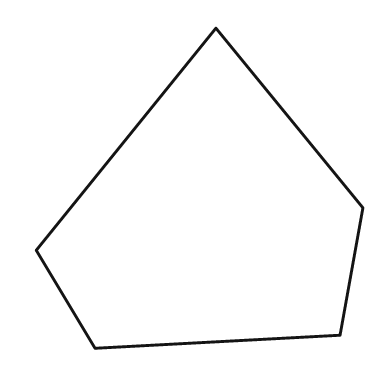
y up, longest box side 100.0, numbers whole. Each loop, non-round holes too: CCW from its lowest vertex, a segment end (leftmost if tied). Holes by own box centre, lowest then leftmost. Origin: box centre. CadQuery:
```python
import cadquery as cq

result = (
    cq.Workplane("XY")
    .moveTo(-32.0, -49.0)
    .lineTo(43.0, -45.0)
    .lineTo(50.0, -6.0)
    .lineTo(5.0, 49.0)
    .lineTo(-50.0, -19.0)
    .close()
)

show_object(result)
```